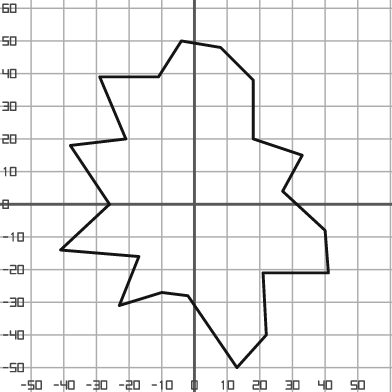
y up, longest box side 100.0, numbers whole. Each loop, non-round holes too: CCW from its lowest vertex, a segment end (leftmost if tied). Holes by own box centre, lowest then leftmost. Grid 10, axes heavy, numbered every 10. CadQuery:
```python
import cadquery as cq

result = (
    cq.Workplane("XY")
    .moveTo(13.0, -50.0)
    .lineTo(22.0, -40.0)
    .lineTo(21.0, -21.0)
    .lineTo(41.0, -21.0)
    .lineTo(40.0, -8.0)
    .lineTo(27.0, 4.0)
    .lineTo(33.0, 15.0)
    .lineTo(18.0, 20.0)
    .lineTo(18.0, 38.0)
    .lineTo(8.0, 48.0)
    .lineTo(-4.0, 50.0)
    .lineTo(-11.0, 39.0)
    .lineTo(-29.0, 39.0)
    .lineTo(-21.0, 20.0)
    .lineTo(-38.0, 18.0)
    .lineTo(-26.0, 0.0)
    .lineTo(-41.0, -14.0)
    .lineTo(-17.0, -16.0)
    .lineTo(-23.0, -31.0)
    .lineTo(-10.0, -27.0)
    .lineTo(-2.0, -28.0)
    .close()
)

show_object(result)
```